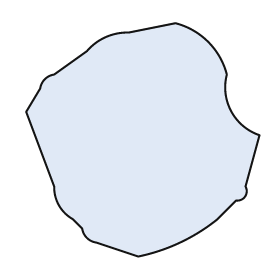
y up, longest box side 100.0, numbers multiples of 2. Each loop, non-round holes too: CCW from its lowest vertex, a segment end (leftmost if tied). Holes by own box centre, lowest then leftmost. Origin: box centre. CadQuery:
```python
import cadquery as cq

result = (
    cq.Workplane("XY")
    .moveTo(-2.0, -50.0)
    .threePointArc((16.0, -44.0), (32.0, -34.0))
    .lineTo(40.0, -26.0)
    .threePointArc((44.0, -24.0), (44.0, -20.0))
    .lineTo(50.0, 2.0)
    .threePointArc((38.0, 12.0), (36.0, 28.0))
    .threePointArc((28.0, 42.0), (14.0, 50.0))
    .lineTo(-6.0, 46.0)
    .threePointArc((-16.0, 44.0), (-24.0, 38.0))
    .lineTo(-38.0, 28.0)
    .threePointArc((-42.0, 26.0), (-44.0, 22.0))
    .lineTo(-50.0, 12.0)
    .lineTo(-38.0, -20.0)
    .threePointArc((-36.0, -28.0), (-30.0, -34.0))
    .lineTo(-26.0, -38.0)
    .threePointArc((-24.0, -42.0), (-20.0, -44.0))
    .close()
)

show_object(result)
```